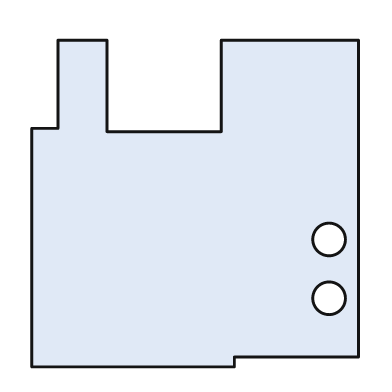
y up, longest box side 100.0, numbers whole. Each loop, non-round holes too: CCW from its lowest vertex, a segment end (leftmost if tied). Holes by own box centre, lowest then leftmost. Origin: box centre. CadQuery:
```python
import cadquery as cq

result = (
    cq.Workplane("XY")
    .moveTo(-50.0, -50.0)
    .lineTo(12.0, -50.0)
    .lineTo(12.0, -47.0)
    .lineTo(50.0, -47.0)
    .lineTo(50.0, 50.0)
    .lineTo(8.0, 50.0)
    .lineTo(8.0, 22.0)
    .lineTo(-27.0, 22.0)
    .lineTo(-27.0, 50.0)
    .lineTo(-42.0, 50.0)
    .lineTo(-42.0, 23.0)
    .lineTo(-50.0, 23.0)
    .close()
    .moveTo(41.0, -29.0)
    .circle(5.0)
    .moveTo(41.0, -11.0)
    .circle(5.0)
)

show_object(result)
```